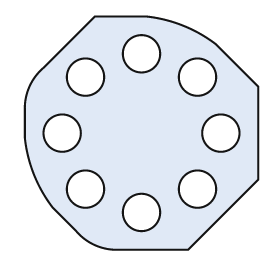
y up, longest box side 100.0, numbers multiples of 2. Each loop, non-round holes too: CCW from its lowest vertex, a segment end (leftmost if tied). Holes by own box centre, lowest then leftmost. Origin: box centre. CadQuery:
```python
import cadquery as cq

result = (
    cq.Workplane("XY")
    .moveTo(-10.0, -50.0)
    .lineTo(20.0, -50.0)
    .lineTo(50.0, -20.0)
    .lineTo(50.0, 20.0)
    .lineTo(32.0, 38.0)
    .threePointArc((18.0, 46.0), (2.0, 50.0))
    .lineTo(-20.0, 50.0)
    .lineTo(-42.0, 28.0)
    .threePointArc((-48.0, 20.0), (-50.0, 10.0))
    .lineTo(-50.0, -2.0)
    .threePointArc((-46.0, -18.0), (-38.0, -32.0))
    .lineTo(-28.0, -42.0)
    .threePointArc((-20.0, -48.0), (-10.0, -50.0))
    .close()
    .moveTo(0.0, -34.0)
    .circle(8.0)
    .moveTo(-24.0, -24.0)
    .circle(8.0)
    .moveTo(24.0, -24.0)
    .circle(8.0)
    .moveTo(-34.0, 0.0)
    .circle(8.0)
    .moveTo(34.0, 0.0)
    .circle(8.0)
    .moveTo(-24.0, 24.0)
    .circle(8.0)
    .moveTo(24.0, 24.0)
    .circle(8.0)
    .moveTo(0.0, 34.0)
    .circle(8.0)
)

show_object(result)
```